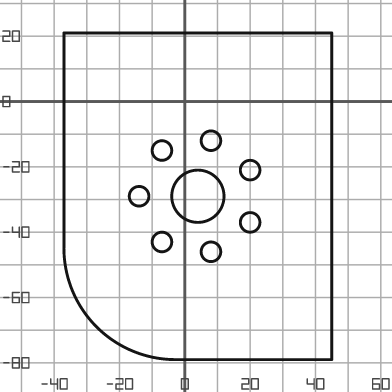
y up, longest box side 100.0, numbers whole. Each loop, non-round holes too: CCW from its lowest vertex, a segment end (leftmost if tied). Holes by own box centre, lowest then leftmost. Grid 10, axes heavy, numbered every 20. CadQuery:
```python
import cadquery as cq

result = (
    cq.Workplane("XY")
    .moveTo(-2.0, -79.0)
    .lineTo(45.0, -79.0)
    .lineTo(45.0, 21.0)
    .lineTo(-37.0, 21.0)
    .lineTo(-37.0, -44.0)
    .threePointArc((-27.0, -69.0), (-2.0, -79.0))
    .close()
    .moveTo(8.0, -46.0)
    .circle(3.0)
    .moveTo(-7.0, -43.0)
    .circle(3.0)
    .moveTo(20.0, -37.0)
    .circle(3.0)
    .moveTo(-14.0, -29.0)
    .circle(3.0)
    .moveTo(4.0, -29.0)
    .circle(8.0)
    .moveTo(20.0, -21.0)
    .circle(3.0)
    .moveTo(-7.0, -15.0)
    .circle(3.0)
    .moveTo(8.0, -12.0)
    .circle(3.0)
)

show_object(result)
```